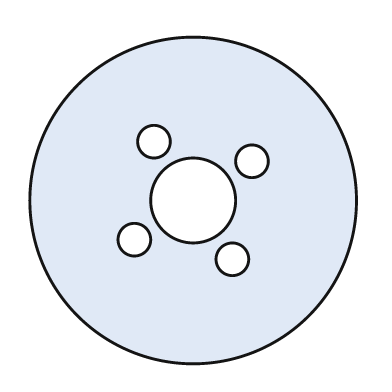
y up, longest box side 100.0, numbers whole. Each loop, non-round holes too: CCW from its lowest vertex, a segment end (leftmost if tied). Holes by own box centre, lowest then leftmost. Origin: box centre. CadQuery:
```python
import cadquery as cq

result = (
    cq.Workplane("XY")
    .moveTo(0.0, 0.0)
    .circle(50.0)
    .moveTo(12.0, -18.0)
    .circle(5.0)
    .moveTo(-18.0, -12.0)
    .circle(5.0)
    .moveTo(0.0, 0.0)
    .circle(13.0)
    .moveTo(18.0, 12.0)
    .circle(5.0)
    .moveTo(-12.0, 18.0)
    .circle(5.0)
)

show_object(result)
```